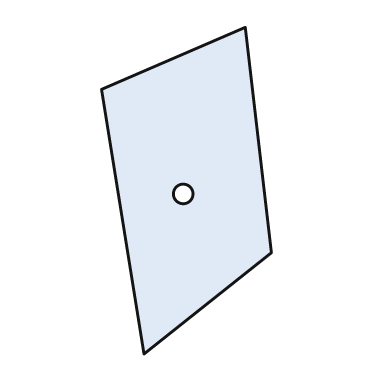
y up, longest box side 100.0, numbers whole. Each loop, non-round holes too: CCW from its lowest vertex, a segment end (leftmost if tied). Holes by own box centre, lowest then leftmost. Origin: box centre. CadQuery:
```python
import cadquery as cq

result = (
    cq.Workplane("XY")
    .moveTo(-13.0, -50.0)
    .lineTo(26.0, -19.0)
    .lineTo(18.0, 50.0)
    .lineTo(-26.0, 31.0)
    .close()
    .moveTo(-1.0, -1.0)
    .circle(3.0)
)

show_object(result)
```